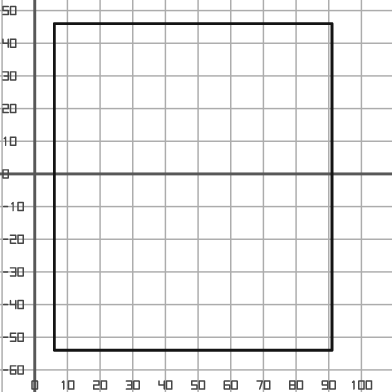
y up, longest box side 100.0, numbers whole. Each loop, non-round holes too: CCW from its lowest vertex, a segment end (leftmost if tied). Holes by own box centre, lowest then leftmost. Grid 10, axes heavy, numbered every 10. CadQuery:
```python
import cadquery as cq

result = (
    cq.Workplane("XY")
    .moveTo(6.0, -54.0)
    .lineTo(91.0, -54.0)
    .lineTo(91.0, 46.0)
    .lineTo(6.0, 46.0)
    .close()
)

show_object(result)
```